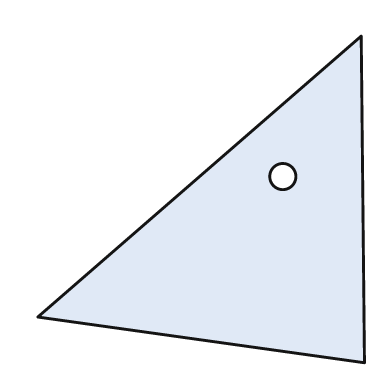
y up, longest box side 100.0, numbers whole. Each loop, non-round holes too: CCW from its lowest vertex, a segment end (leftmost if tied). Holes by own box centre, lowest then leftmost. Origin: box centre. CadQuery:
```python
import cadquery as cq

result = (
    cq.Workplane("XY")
    .moveTo(50.0, -50.0)
    .lineTo(49.0, 50.0)
    .lineTo(-50.0, -36.0)
    .close()
    .moveTo(25.0, 7.0)
    .circle(4.0)
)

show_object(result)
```